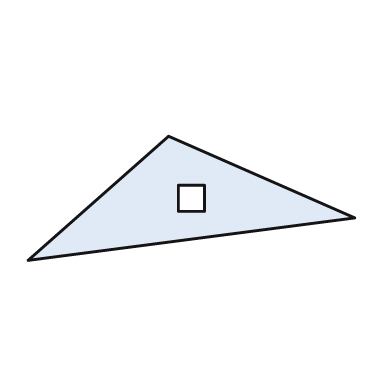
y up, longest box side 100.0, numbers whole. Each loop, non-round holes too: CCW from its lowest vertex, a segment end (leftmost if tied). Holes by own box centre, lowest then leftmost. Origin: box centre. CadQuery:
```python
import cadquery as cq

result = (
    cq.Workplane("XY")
    .moveTo(-50.0, -19.0)
    .lineTo(50.0, -6.0)
    .lineTo(-7.0, 19.0)
    .close()
    .moveTo(-4.0, -4.0)
    .lineTo(4.0, -4.0)
    .lineTo(4.0, 4.0)
    .lineTo(-4.0, 4.0)
    .close()
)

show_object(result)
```